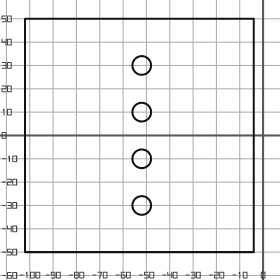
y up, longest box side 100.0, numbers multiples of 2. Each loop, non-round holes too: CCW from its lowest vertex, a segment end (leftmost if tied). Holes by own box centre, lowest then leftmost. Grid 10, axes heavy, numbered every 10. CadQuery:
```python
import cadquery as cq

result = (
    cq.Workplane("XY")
    .moveTo(-102.0, -50.0)
    .lineTo(-4.0, -50.0)
    .lineTo(-4.0, 50.0)
    .lineTo(-102.0, 50.0)
    .close()
    .moveTo(-52.0, -30.0)
    .circle(4.0)
    .moveTo(-52.0, -10.0)
    .circle(4.0)
    .moveTo(-52.0, 10.0)
    .circle(4.0)
    .moveTo(-52.0, 30.0)
    .circle(4.0)
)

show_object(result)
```